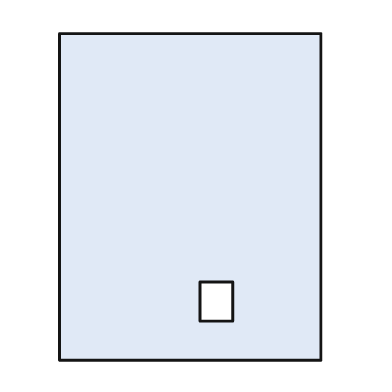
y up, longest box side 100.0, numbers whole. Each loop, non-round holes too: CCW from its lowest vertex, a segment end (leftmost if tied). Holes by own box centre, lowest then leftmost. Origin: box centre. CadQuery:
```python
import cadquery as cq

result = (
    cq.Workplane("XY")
    .moveTo(-40.0, -50.0)
    .lineTo(40.0, -50.0)
    .lineTo(40.0, 50.0)
    .lineTo(-40.0, 50.0)
    .close()
    .moveTo(3.0, -38.0)
    .lineTo(13.0, -38.0)
    .lineTo(13.0, -26.0)
    .lineTo(3.0, -26.0)
    .close()
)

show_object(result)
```